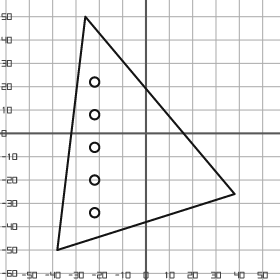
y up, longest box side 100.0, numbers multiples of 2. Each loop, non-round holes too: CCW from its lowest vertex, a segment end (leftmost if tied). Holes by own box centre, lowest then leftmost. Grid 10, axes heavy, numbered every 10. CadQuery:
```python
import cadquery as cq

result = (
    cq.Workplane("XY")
    .moveTo(-38.0, -50.0)
    .lineTo(38.0, -26.0)
    .lineTo(-26.0, 50.0)
    .close()
    .moveTo(-22.0, -34.0)
    .circle(2.0)
    .moveTo(-22.0, -20.0)
    .circle(2.0)
    .moveTo(-22.0, -6.0)
    .circle(2.0)
    .moveTo(-22.0, 8.0)
    .circle(2.0)
    .moveTo(-22.0, 22.0)
    .circle(2.0)
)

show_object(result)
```